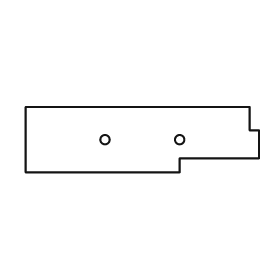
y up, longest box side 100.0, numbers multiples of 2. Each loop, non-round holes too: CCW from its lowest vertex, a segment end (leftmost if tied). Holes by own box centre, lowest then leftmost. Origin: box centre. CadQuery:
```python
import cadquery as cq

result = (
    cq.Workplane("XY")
    .moveTo(-50.0, -14.0)
    .lineTo(16.0, -14.0)
    .lineTo(16.0, -8.0)
    .lineTo(50.0, -8.0)
    .lineTo(50.0, 4.0)
    .lineTo(46.0, 4.0)
    .lineTo(46.0, 14.0)
    .lineTo(-50.0, 14.0)
    .close()
    .moveTo(-16.0, 0.0)
    .circle(2.0)
    .moveTo(16.0, 0.0)
    .circle(2.0)
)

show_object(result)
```